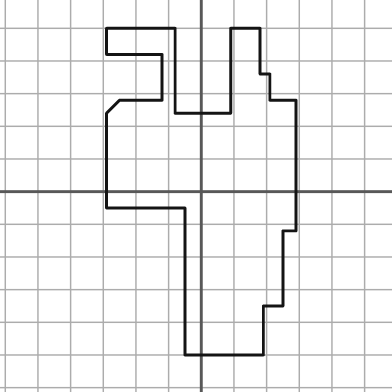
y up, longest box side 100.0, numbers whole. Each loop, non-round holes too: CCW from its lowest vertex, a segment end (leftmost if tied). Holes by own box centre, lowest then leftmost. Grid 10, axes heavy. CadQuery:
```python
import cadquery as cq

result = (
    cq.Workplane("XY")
    .moveTo(-5.0, -50.0)
    .lineTo(19.0, -50.0)
    .lineTo(19.0, -35.0)
    .lineTo(25.0, -35.0)
    .lineTo(25.0, -12.0)
    .lineTo(29.0, -12.0)
    .lineTo(29.0, 28.0)
    .lineTo(21.0, 28.0)
    .lineTo(21.0, 36.0)
    .lineTo(18.0, 36.0)
    .lineTo(18.0, 50.0)
    .lineTo(9.0, 50.0)
    .lineTo(9.0, 24.0)
    .lineTo(-8.0, 24.0)
    .lineTo(-8.0, 50.0)
    .lineTo(-29.0, 50.0)
    .lineTo(-29.0, 42.0)
    .lineTo(-12.0, 42.0)
    .lineTo(-12.0, 28.0)
    .lineTo(-25.0, 28.0)
    .lineTo(-29.0, 24.0)
    .lineTo(-29.0, -5.0)
    .lineTo(-5.0, -5.0)
    .close()
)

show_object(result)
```